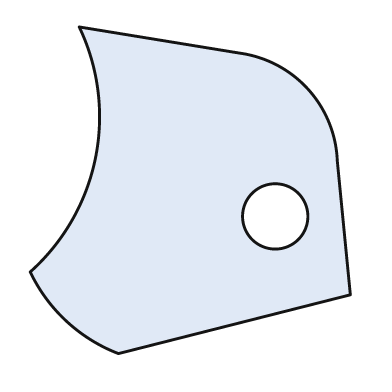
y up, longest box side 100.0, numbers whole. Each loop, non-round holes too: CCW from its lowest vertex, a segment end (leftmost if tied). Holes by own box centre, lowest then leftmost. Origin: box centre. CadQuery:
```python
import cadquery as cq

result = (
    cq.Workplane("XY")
    .moveTo(-22.0, -50.0)
    .lineTo(49.0, -32.0)
    .lineTo(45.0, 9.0)
    .threePointArc((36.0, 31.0), (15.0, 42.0))
    .lineTo(-34.0, 50.0)
    .threePointArc((-29.0, 10.0), (-49.0, -25.0))
    .threePointArc((-38.0, -40.0), (-22.0, -50.0))
    .close()
    .moveTo(26.0, -8.0)
    .circle(10.0)
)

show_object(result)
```